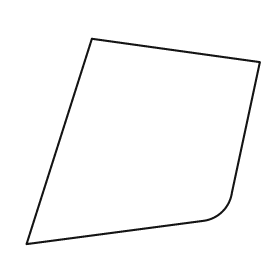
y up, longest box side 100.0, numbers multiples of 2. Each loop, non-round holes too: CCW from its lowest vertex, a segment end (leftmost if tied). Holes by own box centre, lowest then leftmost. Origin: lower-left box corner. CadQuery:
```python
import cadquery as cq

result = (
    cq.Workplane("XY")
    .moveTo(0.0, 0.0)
    .lineTo(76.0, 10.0)
    .threePointArc((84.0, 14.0), (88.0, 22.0))
    .lineTo(100.0, 78.0)
    .lineTo(28.0, 88.0)
    .close()
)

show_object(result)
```